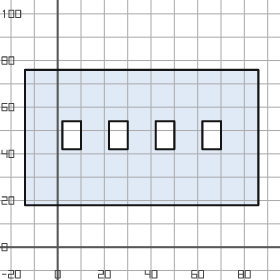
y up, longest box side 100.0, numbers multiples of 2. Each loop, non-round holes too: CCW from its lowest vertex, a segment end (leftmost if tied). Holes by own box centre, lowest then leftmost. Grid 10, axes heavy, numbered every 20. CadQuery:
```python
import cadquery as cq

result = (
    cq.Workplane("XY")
    .moveTo(-14.0, 18.0)
    .lineTo(86.0, 18.0)
    .lineTo(86.0, 76.0)
    .lineTo(-14.0, 76.0)
    .close()
    .moveTo(2.0, 42.0)
    .lineTo(10.0, 42.0)
    .lineTo(10.0, 54.0)
    .lineTo(2.0, 54.0)
    .close()
    .moveTo(22.0, 42.0)
    .lineTo(30.0, 42.0)
    .lineTo(30.0, 54.0)
    .lineTo(22.0, 54.0)
    .close()
    .moveTo(42.0, 42.0)
    .lineTo(50.0, 42.0)
    .lineTo(50.0, 54.0)
    .lineTo(42.0, 54.0)
    .close()
    .moveTo(62.0, 42.0)
    .lineTo(70.0, 42.0)
    .lineTo(70.0, 54.0)
    .lineTo(62.0, 54.0)
    .close()
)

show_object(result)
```